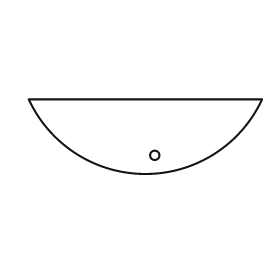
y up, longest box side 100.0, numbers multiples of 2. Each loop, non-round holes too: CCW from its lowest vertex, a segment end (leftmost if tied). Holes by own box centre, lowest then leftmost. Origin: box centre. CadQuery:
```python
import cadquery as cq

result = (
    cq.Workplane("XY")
    .moveTo(-50.0, 16.0)
    .threePointArc((0.0, -16.0), (50.0, 16.0))
    .close()
    .moveTo(4.0, -8.0)
    .circle(2.0)
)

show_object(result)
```